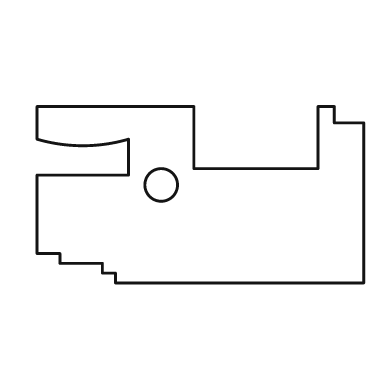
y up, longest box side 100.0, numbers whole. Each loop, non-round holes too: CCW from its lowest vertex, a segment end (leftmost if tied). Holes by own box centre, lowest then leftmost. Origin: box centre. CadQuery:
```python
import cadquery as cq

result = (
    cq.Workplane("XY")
    .moveTo(-26.0, -27.0)
    .lineTo(50.0, -27.0)
    .lineTo(50.0, 22.0)
    .lineTo(41.0, 22.0)
    .lineTo(41.0, 27.0)
    .lineTo(36.0, 27.0)
    .lineTo(36.0, 8.0)
    .lineTo(-2.0, 8.0)
    .lineTo(-2.0, 27.0)
    .lineTo(-50.0, 27.0)
    .lineTo(-50.0, 17.0)
    .threePointArc((-36.0, 15.0), (-22.0, 17.0))
    .lineTo(-22.0, 6.0)
    .lineTo(-50.0, 6.0)
    .lineTo(-50.0, -18.0)
    .lineTo(-43.0, -18.0)
    .lineTo(-43.0, -21.0)
    .lineTo(-30.0, -21.0)
    .lineTo(-30.0, -24.0)
    .lineTo(-26.0, -24.0)
    .close()
    .moveTo(-12.0, 3.0)
    .circle(5.0)
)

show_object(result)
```